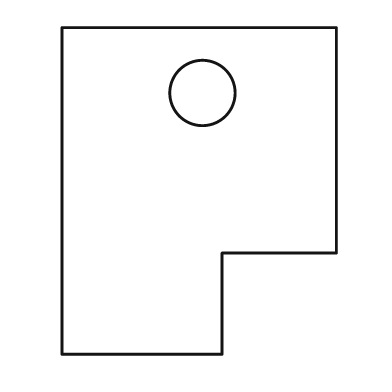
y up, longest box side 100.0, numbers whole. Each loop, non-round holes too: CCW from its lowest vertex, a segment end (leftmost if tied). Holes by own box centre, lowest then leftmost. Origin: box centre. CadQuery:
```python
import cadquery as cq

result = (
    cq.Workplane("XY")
    .moveTo(-42.0, -50.0)
    .lineTo(7.0, -50.0)
    .lineTo(7.0, -19.0)
    .lineTo(42.0, -19.0)
    .lineTo(42.0, 50.0)
    .lineTo(-42.0, 50.0)
    .close()
    .moveTo(1.0, 30.0)
    .circle(10.0)
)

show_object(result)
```